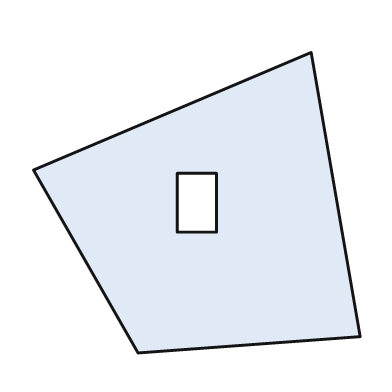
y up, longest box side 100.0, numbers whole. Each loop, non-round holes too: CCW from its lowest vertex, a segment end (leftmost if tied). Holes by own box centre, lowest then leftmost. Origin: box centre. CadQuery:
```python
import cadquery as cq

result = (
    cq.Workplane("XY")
    .moveTo(-18.0, -46.0)
    .lineTo(50.0, -41.0)
    .lineTo(35.0, 46.0)
    .lineTo(-50.0, 10.0)
    .close()
    .moveTo(-6.0, -9.0)
    .lineTo(6.0, -9.0)
    .lineTo(6.0, 9.0)
    .lineTo(-6.0, 9.0)
    .close()
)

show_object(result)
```